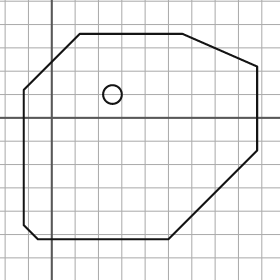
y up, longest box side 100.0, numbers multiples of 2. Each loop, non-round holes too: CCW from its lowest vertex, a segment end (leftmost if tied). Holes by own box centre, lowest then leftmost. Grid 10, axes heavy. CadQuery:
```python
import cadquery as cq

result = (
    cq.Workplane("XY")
    .moveTo(-6.0, -52.0)
    .lineTo(50.0, -52.0)
    .lineTo(88.0, -14.0)
    .lineTo(88.0, 22.0)
    .lineTo(56.0, 36.0)
    .lineTo(12.0, 36.0)
    .lineTo(-12.0, 12.0)
    .lineTo(-12.0, -46.0)
    .close()
    .moveTo(26.0, 10.0)
    .circle(4.0)
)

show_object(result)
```